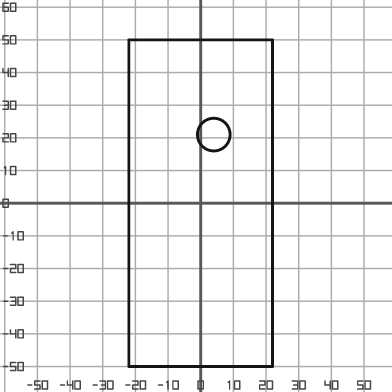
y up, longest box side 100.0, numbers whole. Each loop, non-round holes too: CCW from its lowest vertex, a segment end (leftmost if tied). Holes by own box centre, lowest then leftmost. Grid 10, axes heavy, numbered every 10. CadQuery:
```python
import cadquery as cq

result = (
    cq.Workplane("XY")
    .moveTo(-22.0, -50.0)
    .lineTo(22.0, -50.0)
    .lineTo(22.0, 50.0)
    .lineTo(-22.0, 50.0)
    .close()
    .moveTo(4.0, 21.0)
    .circle(5.0)
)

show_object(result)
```